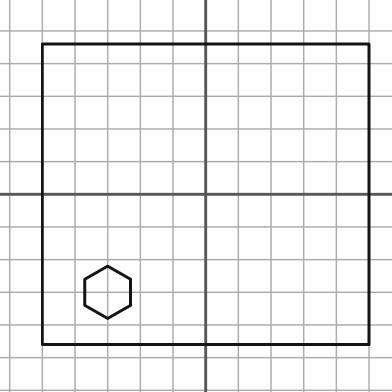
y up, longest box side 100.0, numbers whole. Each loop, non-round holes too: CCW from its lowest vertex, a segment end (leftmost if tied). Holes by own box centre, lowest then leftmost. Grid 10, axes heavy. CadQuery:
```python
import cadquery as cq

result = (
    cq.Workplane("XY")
    .moveTo(-50.0, -46.0)
    .lineTo(50.0, -46.0)
    .lineTo(50.0, 46.0)
    .lineTo(-50.0, 46.0)
    .close()
    .moveTo(-30.0, -38.0)
    .lineTo(-23.0, -34.0)
    .lineTo(-23.0, -26.0)
    .lineTo(-30.0, -22.0)
    .lineTo(-37.0, -26.0)
    .lineTo(-37.0, -34.0)
    .close()
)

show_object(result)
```